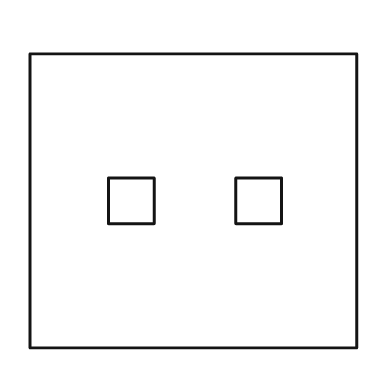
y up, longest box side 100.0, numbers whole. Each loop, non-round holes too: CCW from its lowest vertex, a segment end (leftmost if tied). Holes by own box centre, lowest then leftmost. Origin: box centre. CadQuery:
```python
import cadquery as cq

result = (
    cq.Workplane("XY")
    .moveTo(-50.0, -45.0)
    .lineTo(50.0, -45.0)
    .lineTo(50.0, 45.0)
    .lineTo(-50.0, 45.0)
    .close()
    .moveTo(-26.0, -7.0)
    .lineTo(-12.0, -7.0)
    .lineTo(-12.0, 7.0)
    .lineTo(-26.0, 7.0)
    .close()
    .moveTo(13.0, -7.0)
    .lineTo(27.0, -7.0)
    .lineTo(27.0, 7.0)
    .lineTo(13.0, 7.0)
    .close()
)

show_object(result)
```